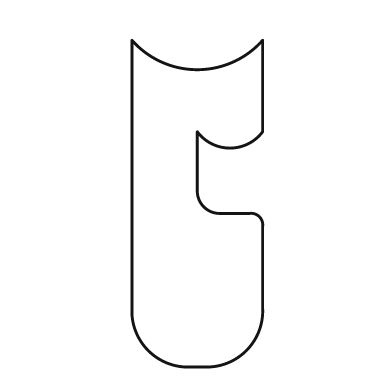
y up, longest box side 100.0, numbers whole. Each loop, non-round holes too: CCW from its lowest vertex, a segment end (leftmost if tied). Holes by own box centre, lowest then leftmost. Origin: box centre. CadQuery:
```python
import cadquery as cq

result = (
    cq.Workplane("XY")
    .moveTo(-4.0, -50.0)
    .lineTo(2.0, -50.0)
    .threePointArc((15.0, -45.0), (20.0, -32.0))
    .lineTo(20.0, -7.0)
    .threePointArc((19.0, -4.0), (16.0, -3.0))
    .lineTo(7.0, -3.0)
    .threePointArc((2.0, -1.0), (0.0, 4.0))
    .lineTo(0.0, 22.0)
    .threePointArc((10.0, 17.0), (20.0, 22.0))
    .lineTo(20.0, 50.0)
    .threePointArc((0.0, 41.0), (-20.0, 50.0))
    .lineTo(-20.0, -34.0)
    .threePointArc((-15.0, -45.0), (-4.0, -50.0))
    .close()
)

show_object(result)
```